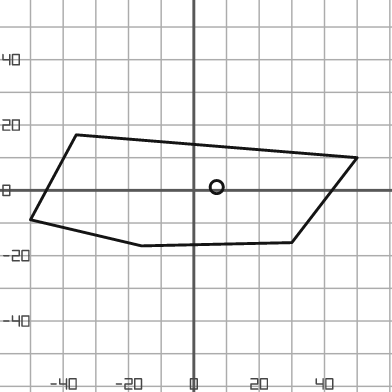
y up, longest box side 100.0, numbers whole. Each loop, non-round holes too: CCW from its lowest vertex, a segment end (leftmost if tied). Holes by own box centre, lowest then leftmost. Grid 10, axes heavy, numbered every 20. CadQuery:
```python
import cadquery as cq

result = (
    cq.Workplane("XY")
    .moveTo(-16.0, -17.0)
    .lineTo(30.0, -16.0)
    .lineTo(50.0, 10.0)
    .lineTo(-36.0, 17.0)
    .lineTo(-50.0, -9.0)
    .close()
    .moveTo(7.0, 1.0)
    .circle(2.0)
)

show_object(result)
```